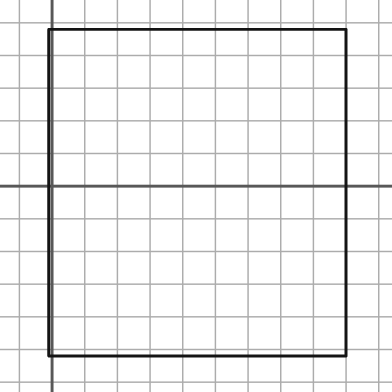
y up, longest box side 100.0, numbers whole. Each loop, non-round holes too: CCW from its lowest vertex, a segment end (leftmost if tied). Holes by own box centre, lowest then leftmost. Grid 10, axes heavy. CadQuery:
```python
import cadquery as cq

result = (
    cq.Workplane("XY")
    .moveTo(-1.0, -52.0)
    .lineTo(90.0, -52.0)
    .lineTo(90.0, 48.0)
    .lineTo(-1.0, 48.0)
    .close()
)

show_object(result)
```